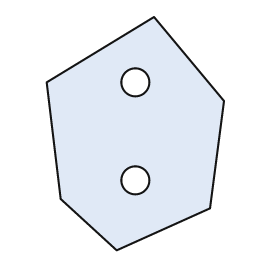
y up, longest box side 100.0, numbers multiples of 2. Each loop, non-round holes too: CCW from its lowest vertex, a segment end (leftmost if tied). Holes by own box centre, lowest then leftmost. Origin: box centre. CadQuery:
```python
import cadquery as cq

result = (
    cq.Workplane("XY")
    .moveTo(-8.0, -50.0)
    .lineTo(32.0, -32.0)
    .lineTo(38.0, 14.0)
    .lineTo(8.0, 50.0)
    .lineTo(-38.0, 22.0)
    .lineTo(-32.0, -28.0)
    .close()
    .moveTo(0.0, -20.0)
    .circle(6.0)
    .moveTo(0.0, 22.0)
    .circle(6.0)
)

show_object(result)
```